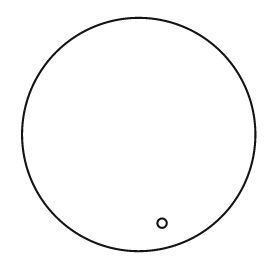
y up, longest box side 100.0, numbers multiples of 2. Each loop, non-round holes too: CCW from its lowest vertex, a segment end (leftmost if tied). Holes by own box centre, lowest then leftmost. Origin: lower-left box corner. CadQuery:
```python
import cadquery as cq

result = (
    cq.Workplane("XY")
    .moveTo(50.0, 50.0)
    .circle(50.0)
    .moveTo(60.0, 12.0)
    .circle(2.0)
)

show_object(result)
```